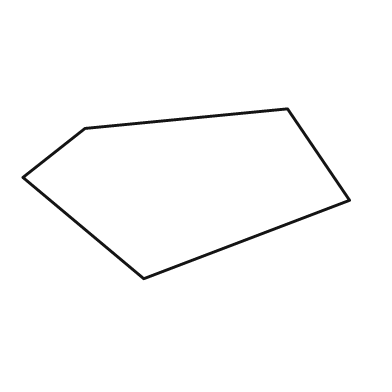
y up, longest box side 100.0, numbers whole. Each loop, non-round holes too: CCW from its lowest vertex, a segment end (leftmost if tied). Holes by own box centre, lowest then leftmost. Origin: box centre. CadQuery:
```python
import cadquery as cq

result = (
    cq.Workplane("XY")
    .moveTo(-13.0, -26.0)
    .lineTo(50.0, -2.0)
    .lineTo(31.0, 26.0)
    .lineTo(-31.0, 20.0)
    .lineTo(-50.0, 5.0)
    .close()
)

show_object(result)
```